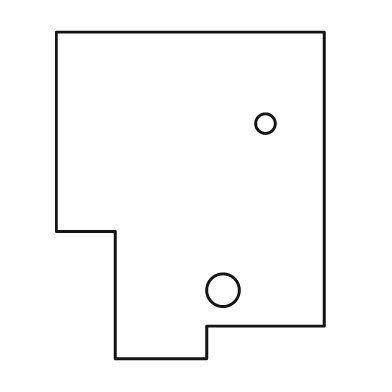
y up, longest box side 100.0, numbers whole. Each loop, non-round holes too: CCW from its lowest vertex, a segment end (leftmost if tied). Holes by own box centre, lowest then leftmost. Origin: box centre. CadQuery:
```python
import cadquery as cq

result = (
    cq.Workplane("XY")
    .moveTo(-23.0, -50.0)
    .lineTo(5.0, -50.0)
    .lineTo(5.0, -40.0)
    .lineTo(41.0, -40.0)
    .lineTo(41.0, 50.0)
    .lineTo(-41.0, 50.0)
    .lineTo(-41.0, -11.0)
    .lineTo(-23.0, -11.0)
    .close()
    .moveTo(10.0, -29.0)
    .circle(5.0)
    .moveTo(23.0, 22.0)
    .circle(3.0)
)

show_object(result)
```